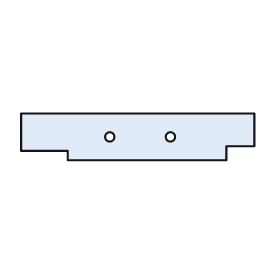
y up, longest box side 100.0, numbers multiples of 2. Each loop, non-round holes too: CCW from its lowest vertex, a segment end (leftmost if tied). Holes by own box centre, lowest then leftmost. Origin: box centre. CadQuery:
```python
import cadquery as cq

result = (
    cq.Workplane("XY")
    .moveTo(-30.0, -10.0)
    .lineTo(38.0, -10.0)
    .lineTo(38.0, -4.0)
    .lineTo(50.0, -4.0)
    .lineTo(50.0, 10.0)
    .lineTo(-50.0, 10.0)
    .lineTo(-50.0, -6.0)
    .lineTo(-30.0, -6.0)
    .close()
    .moveTo(-12.0, 0.0)
    .circle(2.0)
    .moveTo(14.0, 0.0)
    .circle(2.0)
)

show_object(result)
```